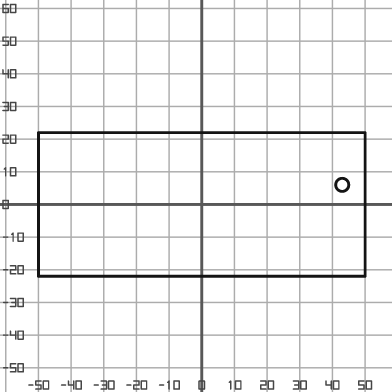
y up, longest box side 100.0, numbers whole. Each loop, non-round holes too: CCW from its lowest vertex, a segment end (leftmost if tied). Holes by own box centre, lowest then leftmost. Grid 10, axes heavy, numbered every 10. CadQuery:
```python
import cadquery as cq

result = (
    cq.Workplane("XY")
    .moveTo(-50.0, -22.0)
    .lineTo(50.0, -22.0)
    .lineTo(50.0, 22.0)
    .lineTo(-50.0, 22.0)
    .close()
    .moveTo(43.0, 6.0)
    .circle(2.0)
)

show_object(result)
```